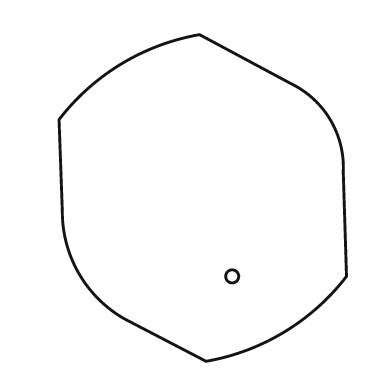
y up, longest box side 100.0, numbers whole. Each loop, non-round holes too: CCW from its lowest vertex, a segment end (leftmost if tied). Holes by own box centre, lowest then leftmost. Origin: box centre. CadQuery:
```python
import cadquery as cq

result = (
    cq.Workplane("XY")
    .moveTo(1.0, -50.0)
    .threePointArc((25.0, -41.0), (44.0, -24.0))
    .lineTo(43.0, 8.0)
    .threePointArc((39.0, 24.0), (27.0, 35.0))
    .lineTo(-1.0, 50.0)
    .threePointArc((-25.0, 41.0), (-44.0, 24.0))
    .lineTo(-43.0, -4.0)
    .threePointArc((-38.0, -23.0), (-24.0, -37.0))
    .close()
    .moveTo(9.0, -24.0)
    .circle(2.0)
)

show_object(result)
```